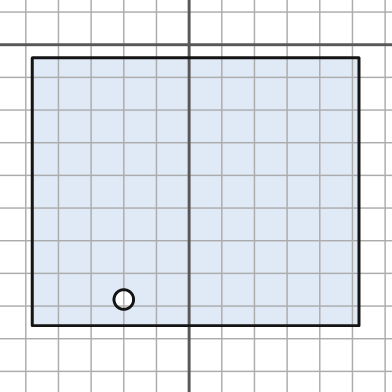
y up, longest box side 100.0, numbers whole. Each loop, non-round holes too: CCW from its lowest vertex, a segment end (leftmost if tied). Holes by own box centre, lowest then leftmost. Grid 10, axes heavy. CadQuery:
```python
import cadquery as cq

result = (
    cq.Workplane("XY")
    .moveTo(-48.0, -86.0)
    .lineTo(52.0, -86.0)
    .lineTo(52.0, -4.0)
    .lineTo(-48.0, -4.0)
    .close()
    .moveTo(-20.0, -78.0)
    .circle(3.0)
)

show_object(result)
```